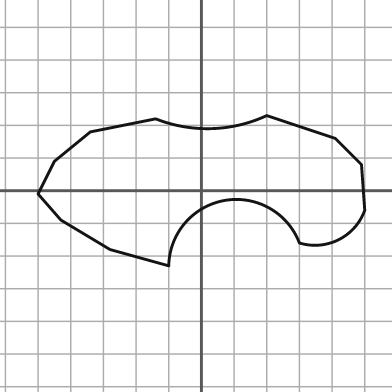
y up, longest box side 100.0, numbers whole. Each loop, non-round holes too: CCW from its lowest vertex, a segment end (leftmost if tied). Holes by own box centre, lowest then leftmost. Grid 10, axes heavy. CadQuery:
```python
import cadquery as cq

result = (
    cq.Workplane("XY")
    .moveTo(-10.0, -23.0)
    .threePointArc((7.0, -3.0), (30.0, -16.0))
    .threePointArc((42.0, -15.0), (50.0, -6.0))
    .lineTo(49.0, 8.0)
    .lineTo(41.0, 16.0)
    .lineTo(20.0, 23.0)
    .threePointArc((3.0, 19.0), (-14.0, 22.0))
    .lineTo(-34.0, 18.0)
    .lineTo(-45.0, 9.0)
    .lineTo(-50.0, -1.0)
    .lineTo(-43.0, -9.0)
    .lineTo(-28.0, -18.0)
    .close()
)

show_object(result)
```